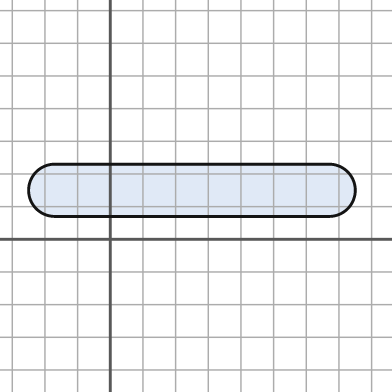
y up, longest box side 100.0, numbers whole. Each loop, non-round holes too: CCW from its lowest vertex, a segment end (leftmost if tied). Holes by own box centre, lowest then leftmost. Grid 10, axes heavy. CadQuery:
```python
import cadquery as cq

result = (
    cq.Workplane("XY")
    .moveTo(-17.0, 7.0)
    .lineTo(67.0, 7.0)
    .threePointArc((75.0, 15.0), (67.0, 23.0))
    .lineTo(-17.0, 23.0)
    .threePointArc((-25.0, 15.0), (-17.0, 7.0))
    .close()
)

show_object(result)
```